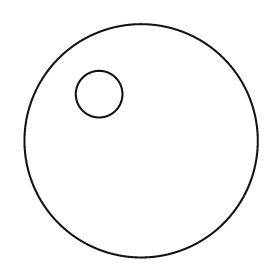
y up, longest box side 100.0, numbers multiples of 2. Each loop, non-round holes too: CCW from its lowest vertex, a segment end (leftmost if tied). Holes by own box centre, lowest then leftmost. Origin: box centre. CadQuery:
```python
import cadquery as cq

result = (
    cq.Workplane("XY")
    .moveTo(0.0, 0.0)
    .circle(50.0)
    .moveTo(-18.0, 20.0)
    .circle(10.0)
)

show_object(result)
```